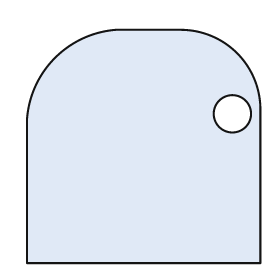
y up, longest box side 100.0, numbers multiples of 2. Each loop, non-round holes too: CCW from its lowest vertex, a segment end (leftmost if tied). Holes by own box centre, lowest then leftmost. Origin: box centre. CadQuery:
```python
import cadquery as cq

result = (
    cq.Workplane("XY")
    .moveTo(-50.0, -50.0)
    .lineTo(50.0, -50.0)
    .lineTo(50.0, 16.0)
    .threePointArc((40.0, 40.0), (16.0, 50.0))
    .lineTo(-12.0, 50.0)
    .threePointArc((-38.0, 38.0), (-50.0, 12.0))
    .close()
    .moveTo(38.0, 14.0)
    .circle(8.0)
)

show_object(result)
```